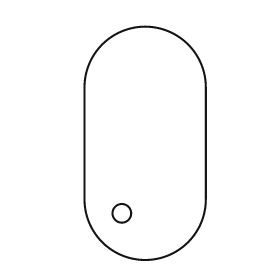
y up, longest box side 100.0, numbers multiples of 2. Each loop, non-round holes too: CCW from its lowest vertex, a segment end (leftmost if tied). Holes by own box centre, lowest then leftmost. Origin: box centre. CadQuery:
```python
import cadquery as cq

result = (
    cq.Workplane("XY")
    .moveTo(-26.0, -24.0)
    .threePointArc((0.0, -50.0), (26.0, -24.0))
    .lineTo(26.0, 24.0)
    .threePointArc((0.0, 50.0), (-26.0, 24.0))
    .close()
    .moveTo(-10.0, -30.0)
    .circle(4.0)
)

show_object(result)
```